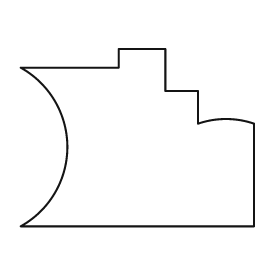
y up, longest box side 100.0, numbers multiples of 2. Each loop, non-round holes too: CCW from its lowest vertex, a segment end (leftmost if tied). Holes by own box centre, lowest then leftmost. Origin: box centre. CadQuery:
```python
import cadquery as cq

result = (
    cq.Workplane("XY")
    .moveTo(-50.0, -38.0)
    .lineTo(50.0, -38.0)
    .lineTo(50.0, 6.0)
    .threePointArc((38.0, 8.0), (26.0, 6.0))
    .lineTo(26.0, 20.0)
    .lineTo(12.0, 20.0)
    .lineTo(12.0, 38.0)
    .lineTo(-8.0, 38.0)
    .lineTo(-8.0, 30.0)
    .lineTo(-50.0, 30.0)
    .threePointArc((-30.0, -4.0), (-50.0, -38.0))
    .close()
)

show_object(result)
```